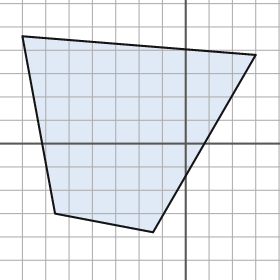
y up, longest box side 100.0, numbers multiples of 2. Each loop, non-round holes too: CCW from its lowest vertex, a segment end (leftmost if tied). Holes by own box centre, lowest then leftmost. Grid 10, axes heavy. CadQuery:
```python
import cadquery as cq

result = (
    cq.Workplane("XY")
    .moveTo(-14.0, -38.0)
    .lineTo(30.0, 38.0)
    .lineTo(-70.0, 46.0)
    .lineTo(-56.0, -30.0)
    .close()
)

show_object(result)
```